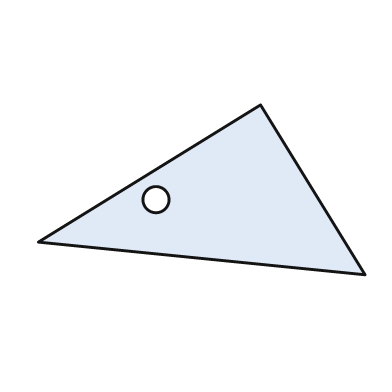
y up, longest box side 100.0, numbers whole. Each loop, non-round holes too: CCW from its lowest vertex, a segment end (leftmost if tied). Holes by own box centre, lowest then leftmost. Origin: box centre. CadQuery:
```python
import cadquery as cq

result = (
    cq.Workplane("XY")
    .moveTo(50.0, -26.0)
    .lineTo(18.0, 26.0)
    .lineTo(-50.0, -16.0)
    .close()
    .moveTo(-14.0, -3.0)
    .circle(4.0)
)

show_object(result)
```